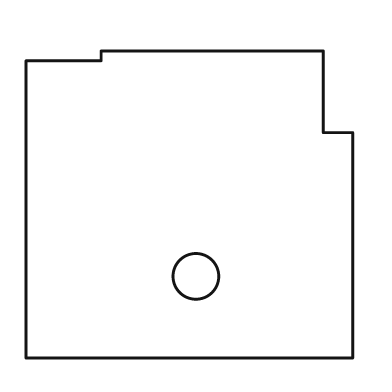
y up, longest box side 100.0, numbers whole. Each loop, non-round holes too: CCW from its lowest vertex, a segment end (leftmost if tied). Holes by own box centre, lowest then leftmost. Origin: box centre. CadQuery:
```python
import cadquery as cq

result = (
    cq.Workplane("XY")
    .moveTo(-50.0, -47.0)
    .lineTo(50.0, -47.0)
    .lineTo(50.0, 22.0)
    .lineTo(41.0, 22.0)
    .lineTo(41.0, 47.0)
    .lineTo(-27.0, 47.0)
    .lineTo(-27.0, 44.0)
    .lineTo(-50.0, 44.0)
    .close()
    .moveTo(2.0, -22.0)
    .circle(7.0)
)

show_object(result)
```